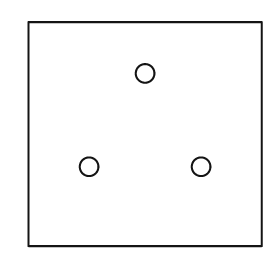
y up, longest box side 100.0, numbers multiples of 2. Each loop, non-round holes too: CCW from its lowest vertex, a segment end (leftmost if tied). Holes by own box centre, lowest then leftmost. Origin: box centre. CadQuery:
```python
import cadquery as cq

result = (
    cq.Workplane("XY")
    .moveTo(-50.0, -48.0)
    .lineTo(50.0, -48.0)
    .lineTo(50.0, 48.0)
    .lineTo(-50.0, 48.0)
    .close()
    .moveTo(-24.0, -14.0)
    .circle(4.0)
    .moveTo(24.0, -14.0)
    .circle(4.0)
    .moveTo(0.0, 26.0)
    .circle(4.0)
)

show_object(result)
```